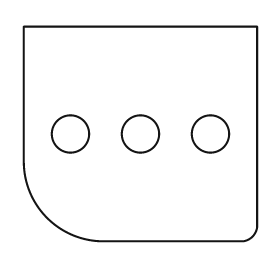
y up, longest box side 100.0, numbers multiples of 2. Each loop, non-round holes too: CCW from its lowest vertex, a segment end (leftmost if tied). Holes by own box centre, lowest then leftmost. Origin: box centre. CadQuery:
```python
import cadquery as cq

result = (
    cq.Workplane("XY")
    .moveTo(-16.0, -46.0)
    .lineTo(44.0, -46.0)
    .threePointArc((48.0, -44.0), (50.0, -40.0))
    .lineTo(50.0, 46.0)
    .lineTo(-50.0, 46.0)
    .lineTo(-50.0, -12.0)
    .threePointArc((-40.0, -36.0), (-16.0, -46.0))
    .close()
    .moveTo(-30.0, 0.0)
    .circle(8.0)
    .moveTo(0.0, 0.0)
    .circle(8.0)
    .moveTo(30.0, 0.0)
    .circle(8.0)
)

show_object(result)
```